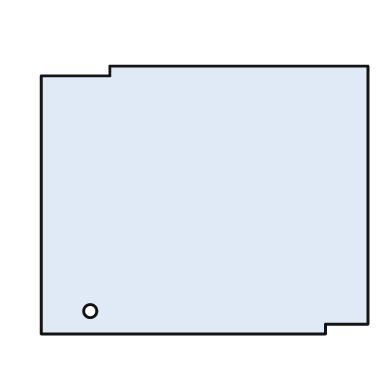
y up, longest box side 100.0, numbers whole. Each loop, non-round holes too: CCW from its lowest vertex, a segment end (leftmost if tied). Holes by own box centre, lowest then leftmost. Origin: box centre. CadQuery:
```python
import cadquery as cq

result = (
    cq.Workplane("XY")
    .moveTo(-50.0, -41.0)
    .lineTo(37.0, -41.0)
    .lineTo(37.0, -38.0)
    .lineTo(50.0, -38.0)
    .lineTo(50.0, 41.0)
    .lineTo(-29.0, 41.0)
    .lineTo(-29.0, 38.0)
    .lineTo(-50.0, 38.0)
    .close()
    .moveTo(-35.0, -34.0)
    .circle(2.0)
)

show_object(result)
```